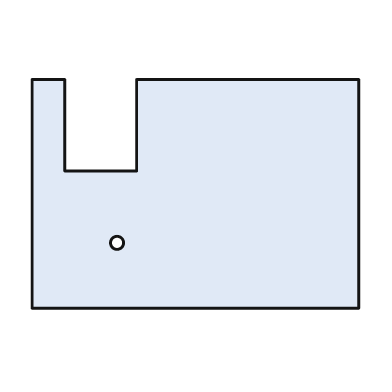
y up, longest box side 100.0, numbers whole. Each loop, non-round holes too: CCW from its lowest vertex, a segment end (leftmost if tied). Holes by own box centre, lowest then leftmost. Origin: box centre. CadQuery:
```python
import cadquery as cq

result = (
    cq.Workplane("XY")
    .moveTo(-50.0, -35.0)
    .lineTo(50.0, -35.0)
    .lineTo(50.0, 35.0)
    .lineTo(-18.0, 35.0)
    .lineTo(-18.0, 7.0)
    .lineTo(-40.0, 7.0)
    .lineTo(-40.0, 35.0)
    .lineTo(-50.0, 35.0)
    .close()
    .moveTo(-24.0, -15.0)
    .circle(2.0)
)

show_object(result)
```